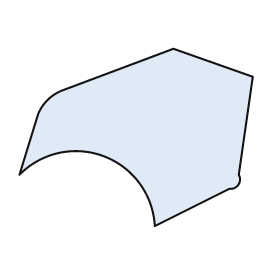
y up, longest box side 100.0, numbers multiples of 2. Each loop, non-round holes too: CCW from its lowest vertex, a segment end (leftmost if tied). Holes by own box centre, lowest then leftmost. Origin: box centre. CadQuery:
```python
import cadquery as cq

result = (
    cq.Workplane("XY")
    .moveTo(8.0, -38.0)
    .lineTo(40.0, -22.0)
    .threePointArc((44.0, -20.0), (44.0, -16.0))
    .lineTo(50.0, 26.0)
    .lineTo(16.0, 38.0)
    .lineTo(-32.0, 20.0)
    .threePointArc((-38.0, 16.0), (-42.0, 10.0))
    .lineTo(-50.0, -16.0)
    .threePointArc((-14.0, -8.0), (8.0, -38.0))
    .close()
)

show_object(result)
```